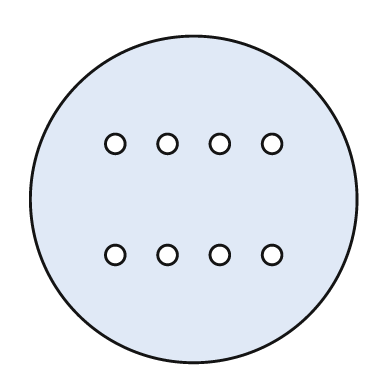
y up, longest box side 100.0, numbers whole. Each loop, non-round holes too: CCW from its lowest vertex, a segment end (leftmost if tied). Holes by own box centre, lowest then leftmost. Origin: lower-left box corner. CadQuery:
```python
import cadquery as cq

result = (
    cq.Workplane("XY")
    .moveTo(50.0, 50.0)
    .circle(50.0)
    .moveTo(26.0, 33.0)
    .circle(3.0)
    .moveTo(42.0, 33.0)
    .circle(3.0)
    .moveTo(58.0, 33.0)
    .circle(3.0)
    .moveTo(74.0, 33.0)
    .circle(3.0)
    .moveTo(26.0, 67.0)
    .circle(3.0)
    .moveTo(42.0, 67.0)
    .circle(3.0)
    .moveTo(58.0, 67.0)
    .circle(3.0)
    .moveTo(74.0, 67.0)
    .circle(3.0)
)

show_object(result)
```